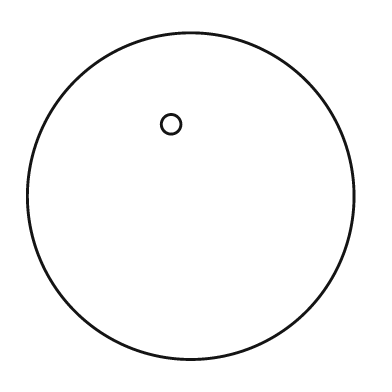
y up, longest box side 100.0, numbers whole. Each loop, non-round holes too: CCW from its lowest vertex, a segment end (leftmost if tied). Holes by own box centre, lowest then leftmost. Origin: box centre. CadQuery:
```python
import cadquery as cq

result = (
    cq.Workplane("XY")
    .moveTo(0.0, 0.0)
    .circle(50.0)
    .moveTo(-6.0, 22.0)
    .circle(3.0)
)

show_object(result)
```